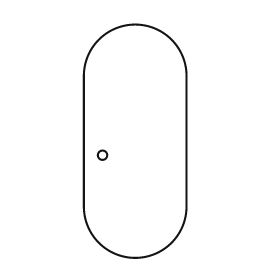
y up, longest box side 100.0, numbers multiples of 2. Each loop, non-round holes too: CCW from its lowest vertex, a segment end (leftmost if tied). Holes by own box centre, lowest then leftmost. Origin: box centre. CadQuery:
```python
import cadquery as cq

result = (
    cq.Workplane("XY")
    .moveTo(-22.0, -28.0)
    .threePointArc((0.0, -50.0), (22.0, -28.0))
    .lineTo(22.0, 28.0)
    .threePointArc((0.0, 50.0), (-22.0, 28.0))
    .close()
    .moveTo(-14.0, -6.0)
    .circle(2.0)
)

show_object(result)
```